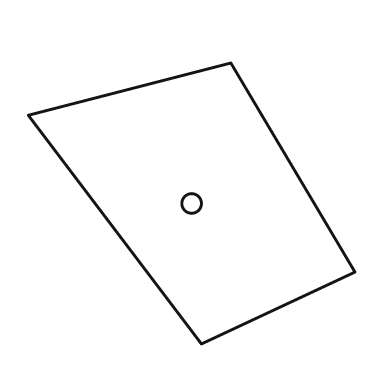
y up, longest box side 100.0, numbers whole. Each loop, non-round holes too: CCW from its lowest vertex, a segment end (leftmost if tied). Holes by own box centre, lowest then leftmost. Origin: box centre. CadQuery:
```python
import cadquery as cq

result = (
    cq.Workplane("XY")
    .moveTo(3.0, -43.0)
    .lineTo(50.0, -21.0)
    .lineTo(12.0, 43.0)
    .lineTo(-50.0, 27.0)
    .close()
    .moveTo(0.0, 0.0)
    .circle(3.0)
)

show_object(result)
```